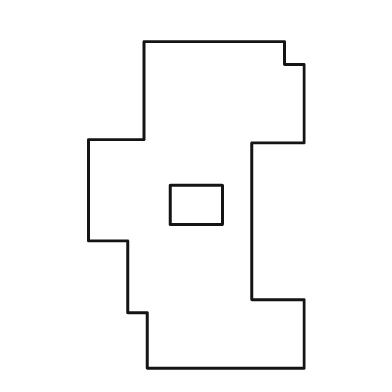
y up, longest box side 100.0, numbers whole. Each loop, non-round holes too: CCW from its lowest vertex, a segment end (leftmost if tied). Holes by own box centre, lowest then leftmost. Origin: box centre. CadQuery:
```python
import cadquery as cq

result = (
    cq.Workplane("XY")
    .moveTo(-15.0, -50.0)
    .lineTo(33.0, -50.0)
    .lineTo(33.0, -29.0)
    .lineTo(17.0, -29.0)
    .lineTo(17.0, 19.0)
    .lineTo(33.0, 19.0)
    .lineTo(33.0, 43.0)
    .lineTo(27.0, 43.0)
    .lineTo(27.0, 50.0)
    .lineTo(-16.0, 50.0)
    .lineTo(-16.0, 20.0)
    .lineTo(-33.0, 20.0)
    .lineTo(-33.0, -11.0)
    .lineTo(-21.0, -11.0)
    .lineTo(-21.0, -33.0)
    .lineTo(-15.0, -33.0)
    .close()
    .moveTo(-8.0, -6.0)
    .lineTo(8.0, -6.0)
    .lineTo(8.0, 6.0)
    .lineTo(-8.0, 6.0)
    .close()
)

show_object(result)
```